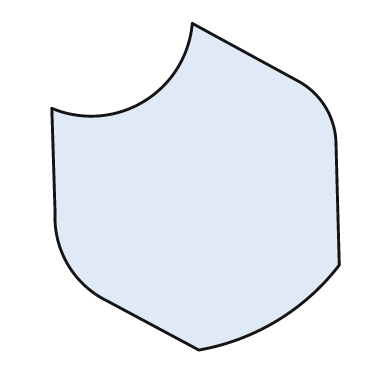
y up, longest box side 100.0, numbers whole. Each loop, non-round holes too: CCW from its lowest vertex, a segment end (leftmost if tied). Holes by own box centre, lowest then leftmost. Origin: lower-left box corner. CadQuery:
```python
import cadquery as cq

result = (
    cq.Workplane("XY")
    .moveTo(45.0, 0.0)
    .threePointArc((69.0, 9.0), (88.0, 26.0))
    .lineTo(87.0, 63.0)
    .threePointArc((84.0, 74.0), (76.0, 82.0))
    .lineTo(43.0, 100.0)
    .threePointArc((28.0, 76.0), (0.0, 74.0))
    .lineTo(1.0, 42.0)
    .threePointArc((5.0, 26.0), (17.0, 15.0))
    .close()
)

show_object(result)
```